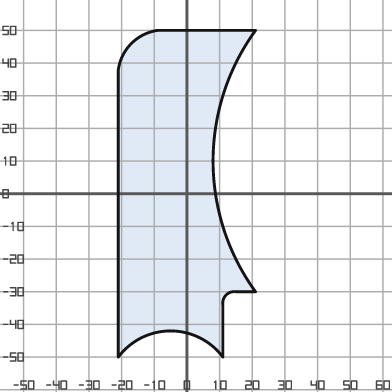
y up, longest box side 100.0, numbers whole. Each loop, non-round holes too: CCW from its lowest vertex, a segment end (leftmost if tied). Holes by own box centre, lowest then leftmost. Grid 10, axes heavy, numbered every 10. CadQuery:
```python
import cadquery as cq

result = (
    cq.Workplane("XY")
    .moveTo(-21.0, -50.0)
    .threePointArc((-5.0, -42.0), (11.0, -50.0))
    .lineTo(11.0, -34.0)
    .threePointArc((12.0, -31.0), (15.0, -30.0))
    .lineTo(21.0, -30.0)
    .threePointArc((8.0, 10.0), (21.0, 50.0))
    .lineTo(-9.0, 50.0)
    .threePointArc((-17.0, 46.0), (-21.0, 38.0))
    .close()
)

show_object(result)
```